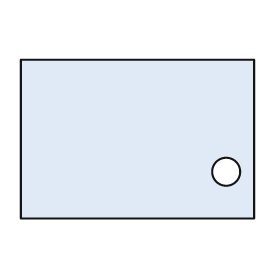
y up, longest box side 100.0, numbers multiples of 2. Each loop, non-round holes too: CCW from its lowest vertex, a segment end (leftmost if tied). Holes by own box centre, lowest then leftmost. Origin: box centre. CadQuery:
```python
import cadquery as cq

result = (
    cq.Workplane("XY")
    .moveTo(-50.0, -34.0)
    .lineTo(50.0, -34.0)
    .lineTo(50.0, 34.0)
    .lineTo(-50.0, 34.0)
    .close()
    .moveTo(38.0, -14.0)
    .circle(6.0)
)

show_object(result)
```